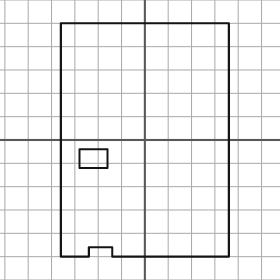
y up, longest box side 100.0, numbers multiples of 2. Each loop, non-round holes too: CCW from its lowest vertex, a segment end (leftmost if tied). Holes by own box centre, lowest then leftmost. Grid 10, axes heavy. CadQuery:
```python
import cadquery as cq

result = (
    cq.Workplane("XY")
    .moveTo(-36.0, -50.0)
    .lineTo(-24.0, -50.0)
    .lineTo(-24.0, -46.0)
    .lineTo(-14.0, -46.0)
    .lineTo(-14.0, -50.0)
    .lineTo(36.0, -50.0)
    .lineTo(36.0, 50.0)
    .lineTo(-36.0, 50.0)
    .close()
    .moveTo(-28.0, -12.0)
    .lineTo(-16.0, -12.0)
    .lineTo(-16.0, -4.0)
    .lineTo(-28.0, -4.0)
    .close()
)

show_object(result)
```